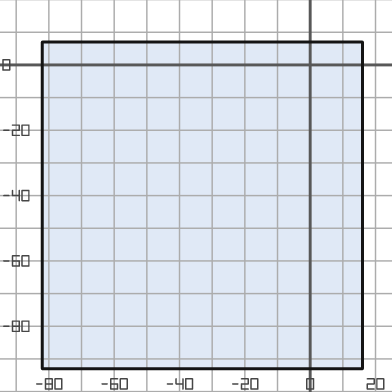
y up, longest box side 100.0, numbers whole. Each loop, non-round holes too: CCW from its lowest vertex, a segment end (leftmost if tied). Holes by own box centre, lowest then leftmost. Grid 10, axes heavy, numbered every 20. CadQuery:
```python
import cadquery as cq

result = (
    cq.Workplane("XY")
    .moveTo(-82.0, -93.0)
    .lineTo(16.0, -93.0)
    .lineTo(16.0, 7.0)
    .lineTo(-82.0, 7.0)
    .close()
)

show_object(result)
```